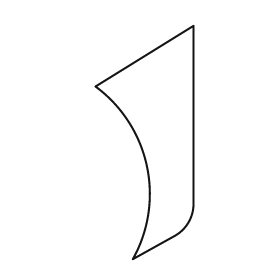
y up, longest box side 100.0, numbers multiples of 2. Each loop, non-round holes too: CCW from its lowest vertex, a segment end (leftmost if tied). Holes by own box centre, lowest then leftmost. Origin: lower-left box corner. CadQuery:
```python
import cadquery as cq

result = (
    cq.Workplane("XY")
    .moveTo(16.0, 0.0)
    .lineTo(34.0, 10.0)
    .threePointArc((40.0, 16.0), (42.0, 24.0))
    .lineTo(42.0, 100.0)
    .lineTo(0.0, 74.0)
    .threePointArc((22.0, 40.0), (16.0, 0.0))
    .close()
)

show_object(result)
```